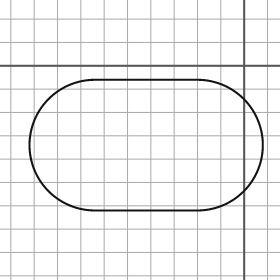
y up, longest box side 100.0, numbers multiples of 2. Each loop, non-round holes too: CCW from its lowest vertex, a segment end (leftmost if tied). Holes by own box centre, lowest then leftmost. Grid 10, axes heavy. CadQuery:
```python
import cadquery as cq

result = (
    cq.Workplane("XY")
    .moveTo(-64.0, -62.0)
    .lineTo(-20.0, -62.0)
    .threePointArc((8.0, -34.0), (-20.0, -6.0))
    .lineTo(-64.0, -6.0)
    .threePointArc((-92.0, -34.0), (-64.0, -62.0))
    .close()
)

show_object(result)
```